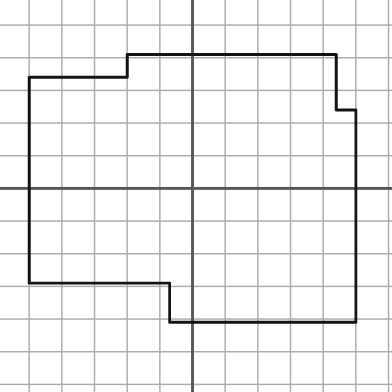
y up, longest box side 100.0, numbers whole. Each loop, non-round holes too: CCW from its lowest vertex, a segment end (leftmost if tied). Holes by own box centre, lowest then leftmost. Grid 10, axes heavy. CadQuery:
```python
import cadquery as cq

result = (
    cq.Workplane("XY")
    .moveTo(-7.0, -41.0)
    .lineTo(50.0, -41.0)
    .lineTo(50.0, 24.0)
    .lineTo(44.0, 24.0)
    .lineTo(44.0, 41.0)
    .lineTo(-20.0, 41.0)
    .lineTo(-20.0, 34.0)
    .lineTo(-50.0, 34.0)
    .lineTo(-50.0, -29.0)
    .lineTo(-7.0, -29.0)
    .close()
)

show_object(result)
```